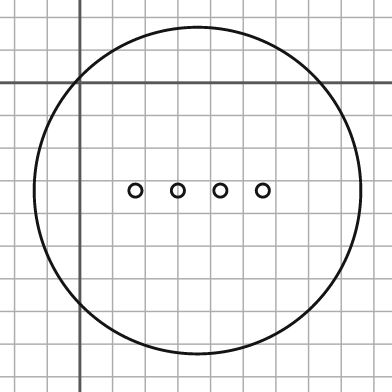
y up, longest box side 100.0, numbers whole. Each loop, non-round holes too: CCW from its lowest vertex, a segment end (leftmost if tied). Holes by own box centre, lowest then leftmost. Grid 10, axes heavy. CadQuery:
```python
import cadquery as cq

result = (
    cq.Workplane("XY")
    .moveTo(36.0, -33.0)
    .circle(50.0)
    .moveTo(17.0, -33.0)
    .circle(2.0)
    .moveTo(30.0, -33.0)
    .circle(2.0)
    .moveTo(43.0, -33.0)
    .circle(2.0)
    .moveTo(56.0, -33.0)
    .circle(2.0)
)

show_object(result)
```